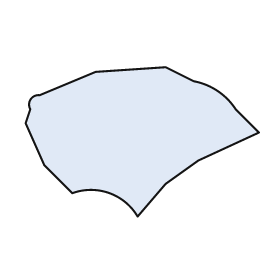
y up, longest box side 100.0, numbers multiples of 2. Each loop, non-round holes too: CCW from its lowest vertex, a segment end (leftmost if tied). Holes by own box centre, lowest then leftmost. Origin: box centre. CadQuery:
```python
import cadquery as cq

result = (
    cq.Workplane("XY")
    .moveTo(-2.0, -32.0)
    .lineTo(10.0, -18.0)
    .lineTo(24.0, -8.0)
    .lineTo(50.0, 4.0)
    .lineTo(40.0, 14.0)
    .threePointArc((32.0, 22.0), (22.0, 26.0))
    .lineTo(10.0, 32.0)
    .lineTo(-20.0, 30.0)
    .lineTo(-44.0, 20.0)
    .threePointArc((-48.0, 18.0), (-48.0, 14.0))
    .lineTo(-50.0, 8.0)
    .lineTo(-42.0, -10.0)
    .lineTo(-30.0, -22.0)
    .threePointArc((-14.0, -22.0), (-2.0, -32.0))
    .close()
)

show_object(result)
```